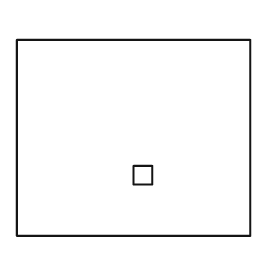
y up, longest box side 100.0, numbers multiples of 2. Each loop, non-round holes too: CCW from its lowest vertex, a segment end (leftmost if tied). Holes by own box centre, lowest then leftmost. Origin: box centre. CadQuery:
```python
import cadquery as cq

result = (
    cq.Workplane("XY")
    .moveTo(-50.0, -42.0)
    .lineTo(50.0, -42.0)
    .lineTo(50.0, 42.0)
    .lineTo(-50.0, 42.0)
    .close()
    .moveTo(0.0, -20.0)
    .lineTo(8.0, -20.0)
    .lineTo(8.0, -12.0)
    .lineTo(0.0, -12.0)
    .close()
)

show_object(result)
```